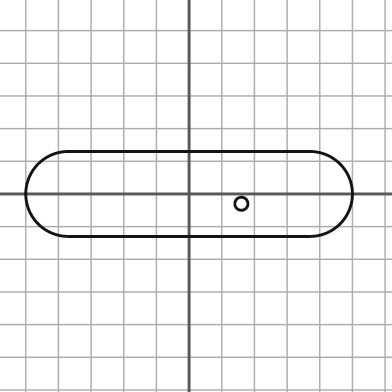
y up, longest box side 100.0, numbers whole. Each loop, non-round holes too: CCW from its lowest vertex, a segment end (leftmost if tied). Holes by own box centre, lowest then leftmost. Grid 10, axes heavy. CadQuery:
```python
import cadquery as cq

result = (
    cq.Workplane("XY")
    .moveTo(-37.0, -13.0)
    .lineTo(37.0, -13.0)
    .threePointArc((50.0, 0.0), (37.0, 13.0))
    .lineTo(-37.0, 13.0)
    .threePointArc((-50.0, 0.0), (-37.0, -13.0))
    .close()
    .moveTo(16.0, -3.0)
    .circle(2.0)
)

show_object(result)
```